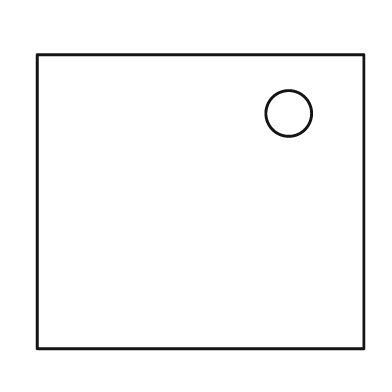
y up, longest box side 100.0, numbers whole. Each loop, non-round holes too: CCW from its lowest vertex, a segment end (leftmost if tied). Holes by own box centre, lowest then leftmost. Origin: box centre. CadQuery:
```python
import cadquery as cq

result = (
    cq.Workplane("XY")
    .moveTo(-50.0, -45.0)
    .lineTo(50.0, -45.0)
    .lineTo(50.0, 45.0)
    .lineTo(-50.0, 45.0)
    .close()
    .moveTo(27.0, 27.0)
    .circle(7.0)
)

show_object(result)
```